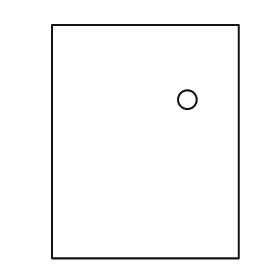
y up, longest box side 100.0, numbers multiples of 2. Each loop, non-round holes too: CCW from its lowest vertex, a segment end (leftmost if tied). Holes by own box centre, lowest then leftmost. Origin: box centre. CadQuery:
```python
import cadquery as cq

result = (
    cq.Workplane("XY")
    .moveTo(-40.0, -50.0)
    .lineTo(40.0, -50.0)
    .lineTo(40.0, 50.0)
    .lineTo(-40.0, 50.0)
    .close()
    .moveTo(18.0, 18.0)
    .circle(4.0)
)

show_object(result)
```